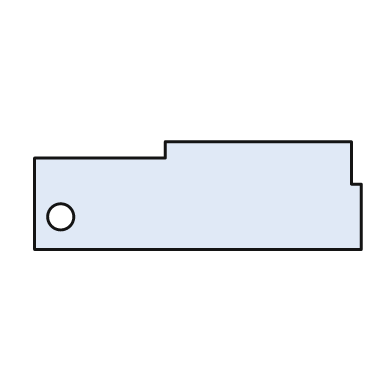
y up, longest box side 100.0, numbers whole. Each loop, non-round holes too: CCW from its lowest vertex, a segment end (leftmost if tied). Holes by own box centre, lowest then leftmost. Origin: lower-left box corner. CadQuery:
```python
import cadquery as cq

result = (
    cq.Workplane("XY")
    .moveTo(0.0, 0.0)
    .lineTo(100.0, 0.0)
    .lineTo(100.0, 20.0)
    .lineTo(97.0, 20.0)
    .lineTo(97.0, 33.0)
    .lineTo(40.0, 33.0)
    .lineTo(40.0, 28.0)
    .lineTo(0.0, 28.0)
    .close()
    .moveTo(8.0, 10.0)
    .circle(4.0)
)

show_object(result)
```